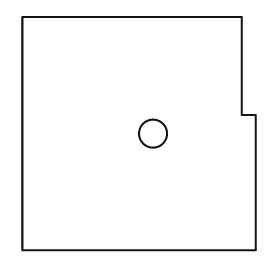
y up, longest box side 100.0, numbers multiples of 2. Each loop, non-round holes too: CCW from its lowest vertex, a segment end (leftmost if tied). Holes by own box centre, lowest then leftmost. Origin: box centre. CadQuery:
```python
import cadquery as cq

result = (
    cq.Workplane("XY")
    .moveTo(-50.0, -50.0)
    .lineTo(50.0, -50.0)
    .lineTo(50.0, 8.0)
    .lineTo(44.0, 8.0)
    .lineTo(44.0, 50.0)
    .lineTo(-50.0, 50.0)
    .close()
    .moveTo(6.0, 0.0)
    .circle(6.0)
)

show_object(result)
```